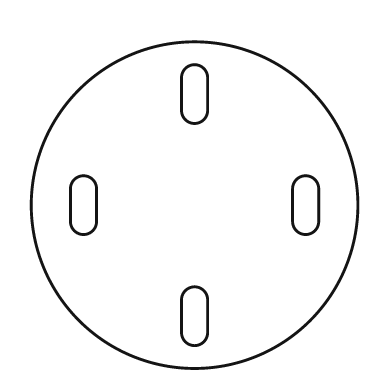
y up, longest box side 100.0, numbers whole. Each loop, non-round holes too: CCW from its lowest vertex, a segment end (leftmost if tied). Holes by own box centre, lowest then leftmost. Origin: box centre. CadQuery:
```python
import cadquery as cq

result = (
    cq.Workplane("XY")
    .moveTo(0.0, 0.0)
    .circle(50.0)
    .moveTo(-4.0, -39.0)
    .threePointArc((0.0, -43.0), (4.0, -39.0))
    .lineTo(4.0, -29.0)
    .threePointArc((0.0, -25.0), (-4.0, -29.0))
    .close()
    .moveTo(-38.0, -5.0)
    .threePointArc((-34.0, -9.0), (-30.0, -5.0))
    .lineTo(-30.0, 5.0)
    .threePointArc((-34.0, 9.0), (-38.0, 5.0))
    .close()
    .moveTo(30.0, -5.0)
    .threePointArc((34.0, -9.0), (38.0, -5.0))
    .lineTo(38.0, 5.0)
    .threePointArc((34.0, 9.0), (30.0, 5.0))
    .close()
    .moveTo(-4.0, 29.0)
    .threePointArc((0.0, 25.0), (4.0, 29.0))
    .lineTo(4.0, 39.0)
    .threePointArc((0.0, 43.0), (-4.0, 39.0))
    .close()
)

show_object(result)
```